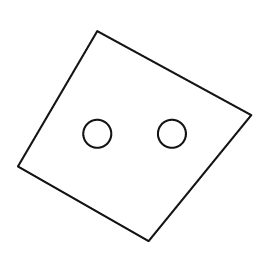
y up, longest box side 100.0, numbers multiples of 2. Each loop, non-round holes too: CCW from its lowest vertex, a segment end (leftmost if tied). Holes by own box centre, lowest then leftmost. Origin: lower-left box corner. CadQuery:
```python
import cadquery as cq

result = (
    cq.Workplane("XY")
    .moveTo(56.0, 0.0)
    .lineTo(100.0, 54.0)
    .lineTo(34.0, 90.0)
    .lineTo(0.0, 32.0)
    .close()
    .moveTo(34.0, 46.0)
    .circle(6.0)
    .moveTo(66.0, 46.0)
    .circle(6.0)
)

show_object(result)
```